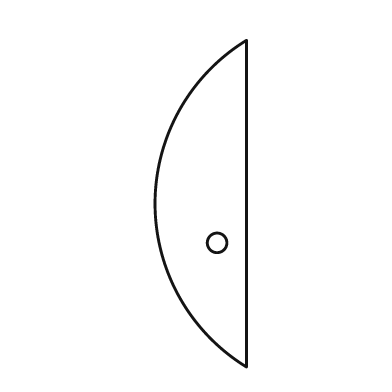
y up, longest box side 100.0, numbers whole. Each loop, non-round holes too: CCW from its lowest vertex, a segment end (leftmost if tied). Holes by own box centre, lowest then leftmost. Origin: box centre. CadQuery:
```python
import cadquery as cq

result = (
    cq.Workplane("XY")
    .moveTo(14.0, -50.0)
    .lineTo(14.0, 50.0)
    .threePointArc((-14.0, 0.0), (14.0, -50.0))
    .close()
    .moveTo(5.0, -12.0)
    .circle(3.0)
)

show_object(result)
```